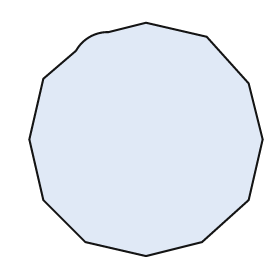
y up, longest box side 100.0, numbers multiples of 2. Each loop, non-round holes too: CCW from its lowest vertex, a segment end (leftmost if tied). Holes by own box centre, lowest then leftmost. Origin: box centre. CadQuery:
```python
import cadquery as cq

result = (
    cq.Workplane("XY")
    .moveTo(0.0, -50.0)
    .lineTo(24.0, -44.0)
    .lineTo(44.0, -26.0)
    .lineTo(50.0, 0.0)
    .lineTo(44.0, 24.0)
    .lineTo(26.0, 44.0)
    .lineTo(0.0, 50.0)
    .lineTo(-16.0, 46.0)
    .threePointArc((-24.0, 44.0), (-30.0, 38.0))
    .lineTo(-44.0, 26.0)
    .lineTo(-50.0, 0.0)
    .lineTo(-44.0, -26.0)
    .lineTo(-26.0, -44.0)
    .close()
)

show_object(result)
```